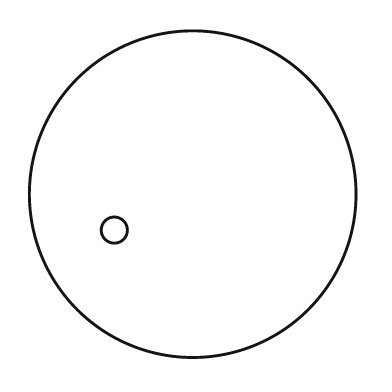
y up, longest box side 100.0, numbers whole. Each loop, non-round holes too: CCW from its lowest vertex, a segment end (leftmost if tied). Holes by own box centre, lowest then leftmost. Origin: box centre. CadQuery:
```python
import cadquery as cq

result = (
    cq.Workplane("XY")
    .moveTo(0.0, 0.0)
    .circle(50.0)
    .moveTo(-24.0, -11.0)
    .circle(4.0)
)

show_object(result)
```